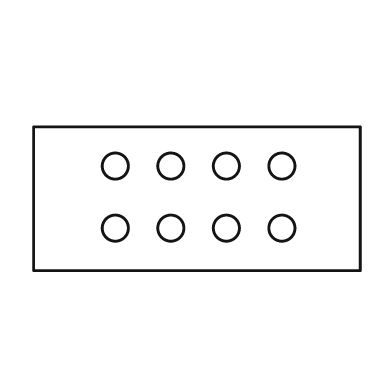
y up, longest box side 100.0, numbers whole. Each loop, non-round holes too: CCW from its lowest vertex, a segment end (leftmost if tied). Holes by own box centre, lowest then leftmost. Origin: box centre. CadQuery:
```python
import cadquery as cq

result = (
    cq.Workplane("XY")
    .moveTo(-50.0, -22.0)
    .lineTo(50.0, -22.0)
    .lineTo(50.0, 22.0)
    .lineTo(-50.0, 22.0)
    .close()
    .moveTo(-25.0, -9.0)
    .circle(4.0)
    .moveTo(-8.0, -9.0)
    .circle(4.0)
    .moveTo(9.0, -9.0)
    .circle(4.0)
    .moveTo(26.0, -9.0)
    .circle(4.0)
    .moveTo(-25.0, 10.0)
    .circle(4.0)
    .moveTo(-8.0, 10.0)
    .circle(4.0)
    .moveTo(9.0, 10.0)
    .circle(4.0)
    .moveTo(26.0, 10.0)
    .circle(4.0)
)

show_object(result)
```